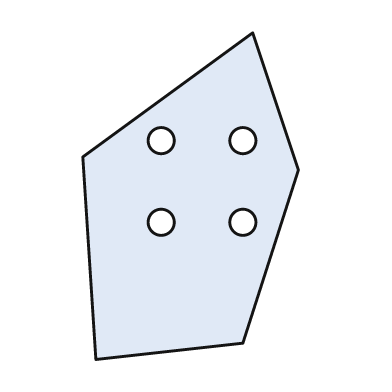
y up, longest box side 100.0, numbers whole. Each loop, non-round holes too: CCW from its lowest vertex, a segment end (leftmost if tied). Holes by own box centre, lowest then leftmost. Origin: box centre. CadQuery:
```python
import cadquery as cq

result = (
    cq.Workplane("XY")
    .moveTo(-29.0, -50.0)
    .lineTo(16.0, -45.0)
    .lineTo(33.0, 8.0)
    .lineTo(19.0, 50.0)
    .lineTo(-33.0, 12.0)
    .close()
    .moveTo(-9.0, -8.0)
    .circle(4.0)
    .moveTo(16.0, -8.0)
    .circle(4.0)
    .moveTo(-9.0, 17.0)
    .circle(4.0)
    .moveTo(16.0, 17.0)
    .circle(4.0)
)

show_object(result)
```